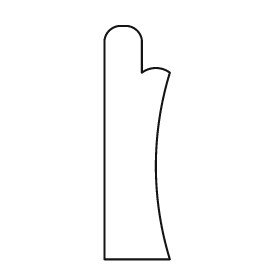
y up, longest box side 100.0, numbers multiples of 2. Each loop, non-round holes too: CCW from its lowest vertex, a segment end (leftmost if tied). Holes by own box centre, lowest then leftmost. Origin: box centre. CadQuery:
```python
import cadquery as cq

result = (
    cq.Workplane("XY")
    .moveTo(-14.0, -50.0)
    .lineTo(14.0, -50.0)
    .threePointArc((8.0, -10.0), (14.0, 30.0))
    .threePointArc((8.0, 32.0), (2.0, 30.0))
    .lineTo(2.0, 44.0)
    .threePointArc((0.0, 48.0), (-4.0, 50.0))
    .lineTo(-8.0, 50.0)
    .threePointArc((-12.0, 48.0), (-14.0, 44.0))
    .close()
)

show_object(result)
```